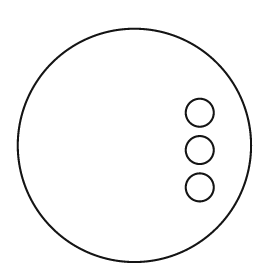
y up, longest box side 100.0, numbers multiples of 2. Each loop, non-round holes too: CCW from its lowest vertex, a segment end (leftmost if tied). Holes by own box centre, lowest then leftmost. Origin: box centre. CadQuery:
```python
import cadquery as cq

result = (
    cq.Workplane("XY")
    .moveTo(0.0, 0.0)
    .circle(50.0)
    .moveTo(28.0, -18.0)
    .circle(6.0)
    .moveTo(28.0, -2.0)
    .circle(6.0)
    .moveTo(28.0, 14.0)
    .circle(6.0)
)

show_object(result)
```